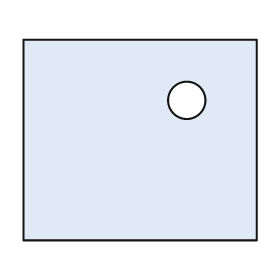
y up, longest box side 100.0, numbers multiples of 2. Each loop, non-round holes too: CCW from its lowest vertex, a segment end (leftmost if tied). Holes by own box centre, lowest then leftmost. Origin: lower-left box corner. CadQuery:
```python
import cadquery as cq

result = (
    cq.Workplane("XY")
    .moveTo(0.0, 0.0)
    .lineTo(100.0, 0.0)
    .lineTo(100.0, 86.0)
    .lineTo(0.0, 86.0)
    .close()
    .moveTo(70.0, 60.0)
    .circle(8.0)
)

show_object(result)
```